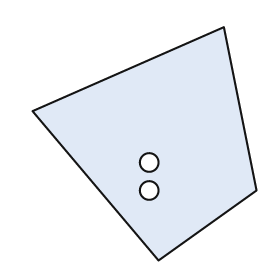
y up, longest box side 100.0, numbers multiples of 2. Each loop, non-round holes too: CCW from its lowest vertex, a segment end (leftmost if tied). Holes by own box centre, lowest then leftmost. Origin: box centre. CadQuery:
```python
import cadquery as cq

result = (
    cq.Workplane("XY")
    .moveTo(6.0, -50.0)
    .lineTo(48.0, -20.0)
    .lineTo(34.0, 50.0)
    .lineTo(-48.0, 14.0)
    .close()
    .moveTo(2.0, -20.0)
    .circle(4.0)
    .moveTo(2.0, -8.0)
    .circle(4.0)
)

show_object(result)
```